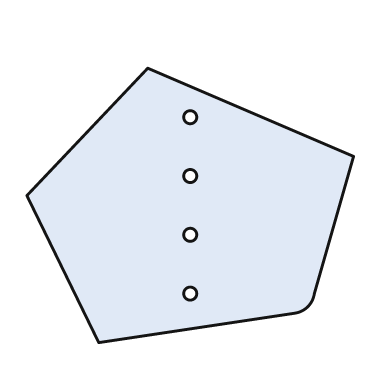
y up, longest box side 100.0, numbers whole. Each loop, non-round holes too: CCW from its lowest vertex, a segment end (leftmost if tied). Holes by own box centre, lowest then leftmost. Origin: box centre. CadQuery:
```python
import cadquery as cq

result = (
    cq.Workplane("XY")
    .moveTo(-28.0, -42.0)
    .lineTo(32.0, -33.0)
    .threePointArc((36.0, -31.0), (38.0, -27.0))
    .lineTo(50.0, 15.0)
    .lineTo(-13.0, 42.0)
    .lineTo(-50.0, 3.0)
    .close()
    .moveTo(0.0, -27.0)
    .circle(2.0)
    .moveTo(0.0, -9.0)
    .circle(2.0)
    .moveTo(0.0, 9.0)
    .circle(2.0)
    .moveTo(0.0, 27.0)
    .circle(2.0)
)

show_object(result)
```